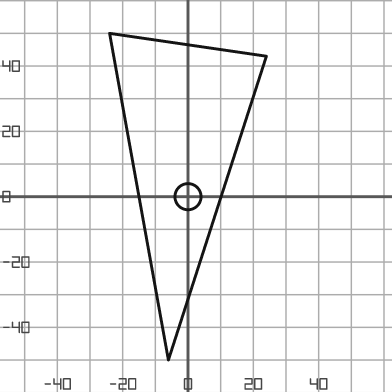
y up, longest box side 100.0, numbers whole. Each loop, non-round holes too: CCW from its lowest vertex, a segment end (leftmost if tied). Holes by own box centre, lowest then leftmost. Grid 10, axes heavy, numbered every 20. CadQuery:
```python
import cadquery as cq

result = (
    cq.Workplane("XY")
    .moveTo(-6.0, -50.0)
    .lineTo(24.0, 43.0)
    .lineTo(-24.0, 50.0)
    .close()
    .moveTo(0.0, 0.0)
    .circle(4.0)
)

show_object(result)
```